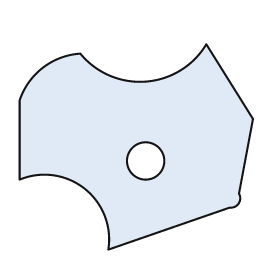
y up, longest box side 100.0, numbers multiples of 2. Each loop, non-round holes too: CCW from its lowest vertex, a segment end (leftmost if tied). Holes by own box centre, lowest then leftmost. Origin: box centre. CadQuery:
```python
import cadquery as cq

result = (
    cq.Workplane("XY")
    .moveTo(-12.0, -44.0)
    .lineTo(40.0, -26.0)
    .threePointArc((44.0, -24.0), (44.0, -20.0))
    .lineTo(50.0, 12.0)
    .lineTo(30.0, 44.0)
    .threePointArc((4.0, 28.0), (-24.0, 40.0))
    .threePointArc((-40.0, 34.0), (-50.0, 20.0))
    .lineTo(-50.0, -14.0)
    .threePointArc((-22.0, -18.0), (-12.0, -44.0))
    .close()
    .moveTo(4.0, -6.0)
    .circle(8.0)
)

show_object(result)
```